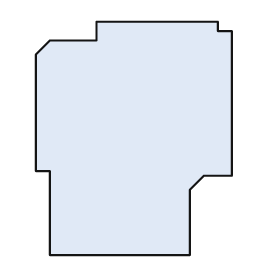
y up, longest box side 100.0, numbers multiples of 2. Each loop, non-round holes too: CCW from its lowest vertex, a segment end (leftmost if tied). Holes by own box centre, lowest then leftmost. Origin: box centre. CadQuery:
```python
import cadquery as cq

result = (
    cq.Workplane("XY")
    .moveTo(-36.0, -50.0)
    .lineTo(24.0, -50.0)
    .lineTo(24.0, -22.0)
    .lineTo(30.0, -16.0)
    .lineTo(42.0, -16.0)
    .lineTo(42.0, 46.0)
    .lineTo(36.0, 46.0)
    .lineTo(36.0, 50.0)
    .lineTo(-16.0, 50.0)
    .lineTo(-16.0, 42.0)
    .lineTo(-36.0, 42.0)
    .lineTo(-42.0, 36.0)
    .lineTo(-42.0, -14.0)
    .lineTo(-36.0, -14.0)
    .close()
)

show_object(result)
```